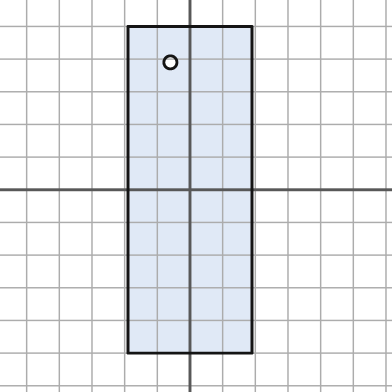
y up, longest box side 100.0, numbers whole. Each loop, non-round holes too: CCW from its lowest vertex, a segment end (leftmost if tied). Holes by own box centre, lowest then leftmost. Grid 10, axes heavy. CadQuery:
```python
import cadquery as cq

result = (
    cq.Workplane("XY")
    .moveTo(-19.0, -50.0)
    .lineTo(19.0, -50.0)
    .lineTo(19.0, 50.0)
    .lineTo(-19.0, 50.0)
    .close()
    .moveTo(-6.0, 39.0)
    .circle(2.0)
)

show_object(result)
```